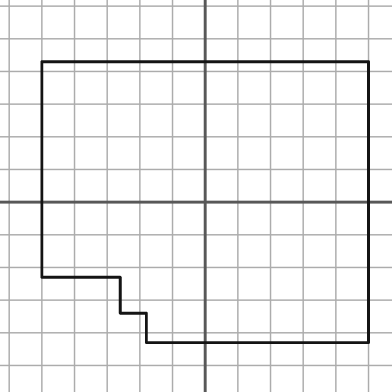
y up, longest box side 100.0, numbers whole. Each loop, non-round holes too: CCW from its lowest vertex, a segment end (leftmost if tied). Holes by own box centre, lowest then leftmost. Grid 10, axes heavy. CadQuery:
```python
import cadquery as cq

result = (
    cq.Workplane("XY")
    .moveTo(-18.0, -43.0)
    .lineTo(50.0, -43.0)
    .lineTo(50.0, 43.0)
    .lineTo(-50.0, 43.0)
    .lineTo(-50.0, -23.0)
    .lineTo(-26.0, -23.0)
    .lineTo(-26.0, -34.0)
    .lineTo(-18.0, -34.0)
    .close()
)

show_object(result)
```